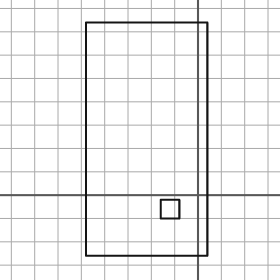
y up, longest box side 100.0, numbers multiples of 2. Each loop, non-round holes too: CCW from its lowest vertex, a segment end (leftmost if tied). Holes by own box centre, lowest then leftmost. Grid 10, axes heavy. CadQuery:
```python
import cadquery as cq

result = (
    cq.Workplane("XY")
    .moveTo(-48.0, -26.0)
    .lineTo(4.0, -26.0)
    .lineTo(4.0, 74.0)
    .lineTo(-48.0, 74.0)
    .close()
    .moveTo(-16.0, -10.0)
    .lineTo(-8.0, -10.0)
    .lineTo(-8.0, -2.0)
    .lineTo(-16.0, -2.0)
    .close()
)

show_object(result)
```